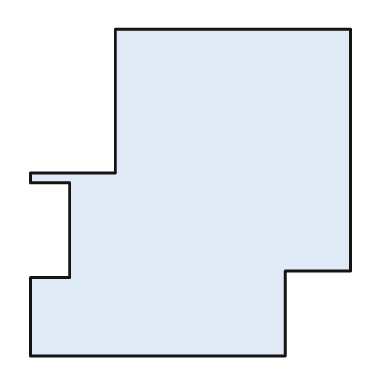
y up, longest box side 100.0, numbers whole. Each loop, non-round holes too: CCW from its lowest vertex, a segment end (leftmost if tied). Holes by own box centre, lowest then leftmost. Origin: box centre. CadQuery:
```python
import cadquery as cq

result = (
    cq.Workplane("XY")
    .moveTo(-49.0, -50.0)
    .lineTo(29.0, -50.0)
    .lineTo(29.0, -24.0)
    .lineTo(49.0, -24.0)
    .lineTo(49.0, 50.0)
    .lineTo(-23.0, 50.0)
    .lineTo(-23.0, 6.0)
    .lineTo(-49.0, 6.0)
    .lineTo(-49.0, 3.0)
    .lineTo(-37.0, 3.0)
    .lineTo(-37.0, -26.0)
    .lineTo(-49.0, -26.0)
    .close()
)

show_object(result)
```